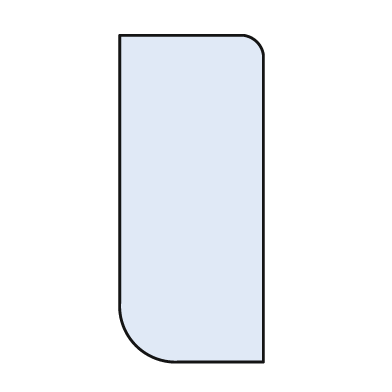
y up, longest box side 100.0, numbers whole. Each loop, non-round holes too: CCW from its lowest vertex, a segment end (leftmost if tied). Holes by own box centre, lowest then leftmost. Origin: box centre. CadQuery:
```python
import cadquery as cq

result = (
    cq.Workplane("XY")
    .moveTo(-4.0, -50.0)
    .lineTo(22.0, -50.0)
    .lineTo(22.0, 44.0)
    .threePointArc((20.0, 48.0), (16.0, 50.0))
    .lineTo(-22.0, 50.0)
    .lineTo(-22.0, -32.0)
    .threePointArc((-17.0, -45.0), (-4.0, -50.0))
    .close()
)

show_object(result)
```